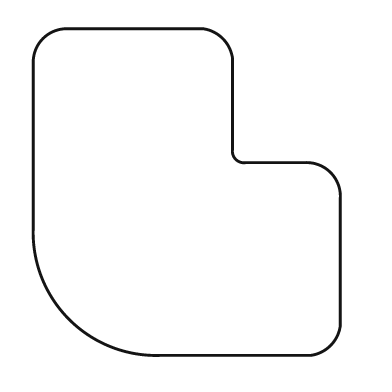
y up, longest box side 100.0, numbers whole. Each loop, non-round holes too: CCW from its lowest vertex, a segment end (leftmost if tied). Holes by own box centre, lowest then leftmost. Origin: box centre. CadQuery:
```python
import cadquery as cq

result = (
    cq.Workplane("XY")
    .moveTo(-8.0, -50.0)
    .lineTo(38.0, -50.0)
    .threePointArc((44.0, -47.0), (47.0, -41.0))
    .lineTo(47.0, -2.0)
    .threePointArc((44.0, 6.0), (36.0, 9.0))
    .lineTo(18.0, 9.0)
    .threePointArc((15.0, 10.0), (14.0, 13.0))
    .lineTo(14.0, 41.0)
    .threePointArc((11.0, 47.0), (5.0, 50.0))
    .lineTo(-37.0, 50.0)
    .threePointArc((-44.0, 47.0), (-47.0, 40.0))
    .lineTo(-47.0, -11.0)
    .threePointArc((-36.0, -39.0), (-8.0, -50.0))
    .close()
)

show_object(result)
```